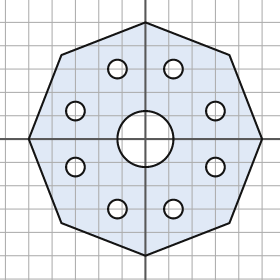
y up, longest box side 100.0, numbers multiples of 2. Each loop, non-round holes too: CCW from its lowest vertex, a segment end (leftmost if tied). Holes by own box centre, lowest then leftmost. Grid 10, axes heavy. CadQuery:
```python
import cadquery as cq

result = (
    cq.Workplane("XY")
    .moveTo(0.0, -50.0)
    .lineTo(36.0, -36.0)
    .lineTo(50.0, 0.0)
    .lineTo(36.0, 36.0)
    .lineTo(0.0, 50.0)
    .lineTo(-36.0, 36.0)
    .lineTo(-50.0, 0.0)
    .lineTo(-36.0, -36.0)
    .close()
    .moveTo(-12.0, -30.0)
    .circle(4.0)
    .moveTo(12.0, -30.0)
    .circle(4.0)
    .moveTo(-30.0, -12.0)
    .circle(4.0)
    .moveTo(30.0, -12.0)
    .circle(4.0)
    .moveTo(0.0, 0.0)
    .circle(12.0)
    .moveTo(-30.0, 12.0)
    .circle(4.0)
    .moveTo(30.0, 12.0)
    .circle(4.0)
    .moveTo(-12.0, 30.0)
    .circle(4.0)
    .moveTo(12.0, 30.0)
    .circle(4.0)
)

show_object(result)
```